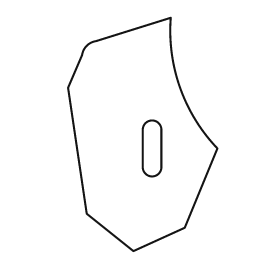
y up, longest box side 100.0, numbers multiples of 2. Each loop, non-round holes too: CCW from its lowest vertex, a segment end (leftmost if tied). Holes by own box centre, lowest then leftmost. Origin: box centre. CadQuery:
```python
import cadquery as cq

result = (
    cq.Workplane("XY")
    .moveTo(-4.0, -50.0)
    .lineTo(18.0, -40.0)
    .lineTo(32.0, -6.0)
    .threePointArc((16.0, 20.0), (12.0, 50.0))
    .lineTo(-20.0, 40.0)
    .threePointArc((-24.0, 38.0), (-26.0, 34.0))
    .lineTo(-32.0, 20.0)
    .lineTo(-24.0, -34.0)
    .close()
    .moveTo(0.0, -14.0)
    .threePointArc((4.0, -18.0), (8.0, -14.0))
    .lineTo(8.0, 2.0)
    .threePointArc((4.0, 6.0), (0.0, 2.0))
    .close()
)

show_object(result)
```